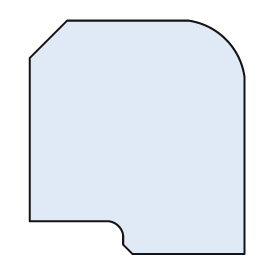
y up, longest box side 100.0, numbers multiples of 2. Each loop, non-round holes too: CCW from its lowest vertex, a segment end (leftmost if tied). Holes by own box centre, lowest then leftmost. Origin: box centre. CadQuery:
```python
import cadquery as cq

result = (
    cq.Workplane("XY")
    .moveTo(-2.0, -50.0)
    .lineTo(46.0, -50.0)
    .lineTo(46.0, 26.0)
    .threePointArc((38.0, 42.0), (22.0, 50.0))
    .lineTo(-30.0, 50.0)
    .lineTo(-46.0, 34.0)
    .lineTo(-46.0, -36.0)
    .lineTo(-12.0, -36.0)
    .threePointArc((-8.0, -38.0), (-6.0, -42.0))
    .lineTo(-6.0, -46.0)
    .close()
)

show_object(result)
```